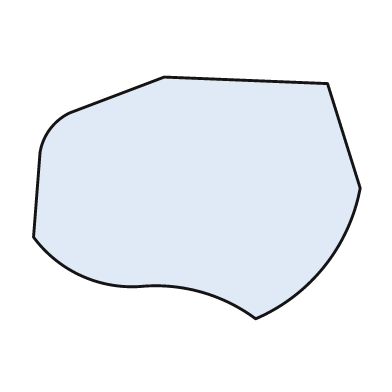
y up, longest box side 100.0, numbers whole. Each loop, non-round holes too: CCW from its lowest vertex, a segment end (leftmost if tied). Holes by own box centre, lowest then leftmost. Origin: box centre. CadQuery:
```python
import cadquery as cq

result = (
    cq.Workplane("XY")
    .moveTo(18.0, -37.0)
    .threePointArc((39.0, -21.0), (50.0, 3.0))
    .lineTo(40.0, 35.0)
    .lineTo(-10.0, 37.0)
    .lineTo(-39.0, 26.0)
    .threePointArc((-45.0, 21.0), (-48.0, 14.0))
    .lineTo(-50.0, -12.0)
    .threePointArc((-35.0, -24.0), (-16.0, -27.0))
    .threePointArc((2.0, -29.0), (18.0, -37.0))
    .close()
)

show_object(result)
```